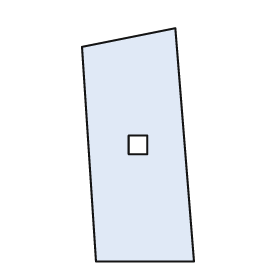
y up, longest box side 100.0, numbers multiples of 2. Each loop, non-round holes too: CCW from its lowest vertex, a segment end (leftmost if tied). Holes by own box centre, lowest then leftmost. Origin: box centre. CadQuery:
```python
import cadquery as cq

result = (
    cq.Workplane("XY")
    .moveTo(-18.0, -50.0)
    .lineTo(24.0, -50.0)
    .lineTo(16.0, 50.0)
    .lineTo(-24.0, 42.0)
    .close()
    .moveTo(-4.0, -4.0)
    .lineTo(4.0, -4.0)
    .lineTo(4.0, 4.0)
    .lineTo(-4.0, 4.0)
    .close()
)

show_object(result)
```